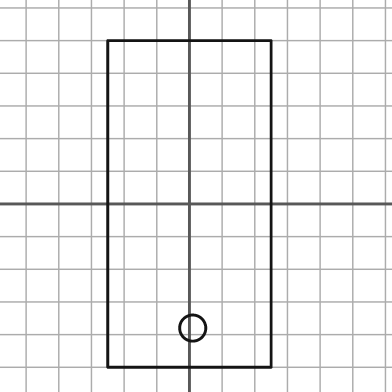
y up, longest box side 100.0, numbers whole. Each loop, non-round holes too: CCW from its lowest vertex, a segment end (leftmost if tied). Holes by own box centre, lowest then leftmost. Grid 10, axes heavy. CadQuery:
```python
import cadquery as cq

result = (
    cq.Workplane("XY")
    .moveTo(-25.0, -50.0)
    .lineTo(25.0, -50.0)
    .lineTo(25.0, 50.0)
    .lineTo(-25.0, 50.0)
    .close()
    .moveTo(1.0, -38.0)
    .circle(4.0)
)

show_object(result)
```